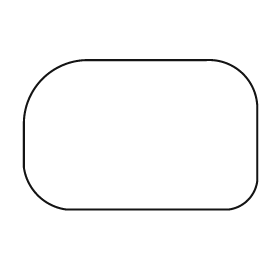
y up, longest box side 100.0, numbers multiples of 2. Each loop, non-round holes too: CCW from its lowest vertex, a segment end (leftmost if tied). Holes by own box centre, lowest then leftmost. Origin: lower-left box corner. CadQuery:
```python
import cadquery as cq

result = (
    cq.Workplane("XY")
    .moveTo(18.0, 0.0)
    .lineTo(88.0, 0.0)
    .threePointArc((96.0, 4.0), (100.0, 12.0))
    .lineTo(100.0, 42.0)
    .threePointArc((94.0, 58.0), (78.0, 64.0))
    .lineTo(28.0, 64.0)
    .threePointArc((8.0, 56.0), (0.0, 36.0))
    .lineTo(0.0, 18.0)
    .threePointArc((6.0, 6.0), (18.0, 0.0))
    .close()
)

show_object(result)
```